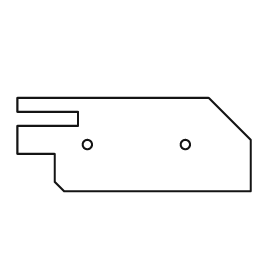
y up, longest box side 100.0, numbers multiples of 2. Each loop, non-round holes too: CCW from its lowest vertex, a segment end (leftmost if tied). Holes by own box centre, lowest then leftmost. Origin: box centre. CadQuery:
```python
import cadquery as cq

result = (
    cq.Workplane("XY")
    .moveTo(-30.0, -20.0)
    .lineTo(50.0, -20.0)
    .lineTo(50.0, 2.0)
    .lineTo(32.0, 20.0)
    .lineTo(-50.0, 20.0)
    .lineTo(-50.0, 14.0)
    .lineTo(-24.0, 14.0)
    .lineTo(-24.0, 8.0)
    .lineTo(-50.0, 8.0)
    .lineTo(-50.0, -4.0)
    .lineTo(-34.0, -4.0)
    .lineTo(-34.0, -16.0)
    .close()
    .moveTo(-20.0, 0.0)
    .circle(2.0)
    .moveTo(22.0, 0.0)
    .circle(2.0)
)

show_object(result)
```